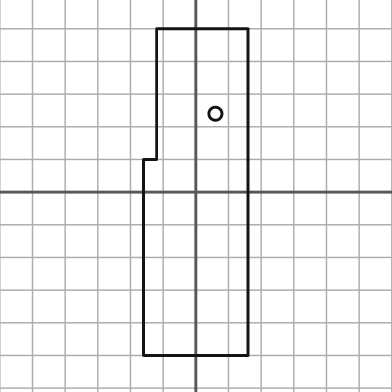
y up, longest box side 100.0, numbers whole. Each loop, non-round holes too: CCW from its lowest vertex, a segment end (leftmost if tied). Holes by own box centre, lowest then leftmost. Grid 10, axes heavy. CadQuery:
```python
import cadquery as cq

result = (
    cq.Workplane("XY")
    .moveTo(-16.0, -50.0)
    .lineTo(16.0, -50.0)
    .lineTo(16.0, 50.0)
    .lineTo(-12.0, 50.0)
    .lineTo(-12.0, 10.0)
    .lineTo(-16.0, 10.0)
    .close()
    .moveTo(6.0, 24.0)
    .circle(2.0)
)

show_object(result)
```